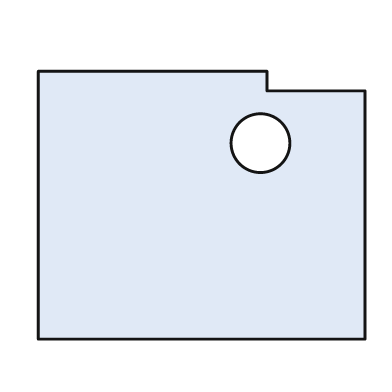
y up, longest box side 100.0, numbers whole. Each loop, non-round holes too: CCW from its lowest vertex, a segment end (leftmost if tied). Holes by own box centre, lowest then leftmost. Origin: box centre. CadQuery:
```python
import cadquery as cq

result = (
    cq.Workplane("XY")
    .moveTo(-50.0, -41.0)
    .lineTo(50.0, -41.0)
    .lineTo(50.0, 35.0)
    .lineTo(20.0, 35.0)
    .lineTo(20.0, 41.0)
    .lineTo(-50.0, 41.0)
    .close()
    .moveTo(18.0, 19.0)
    .circle(9.0)
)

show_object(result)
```